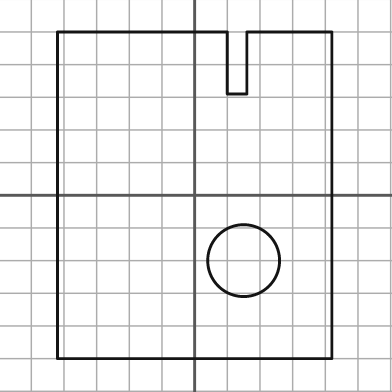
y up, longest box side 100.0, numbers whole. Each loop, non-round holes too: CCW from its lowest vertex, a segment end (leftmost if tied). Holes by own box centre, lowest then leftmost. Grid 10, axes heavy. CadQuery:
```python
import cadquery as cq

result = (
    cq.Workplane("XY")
    .moveTo(-42.0, -50.0)
    .lineTo(42.0, -50.0)
    .lineTo(42.0, 50.0)
    .lineTo(16.0, 50.0)
    .lineTo(16.0, 31.0)
    .lineTo(10.0, 31.0)
    .lineTo(10.0, 50.0)
    .lineTo(-42.0, 50.0)
    .close()
    .moveTo(15.0, -20.0)
    .circle(11.0)
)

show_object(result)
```